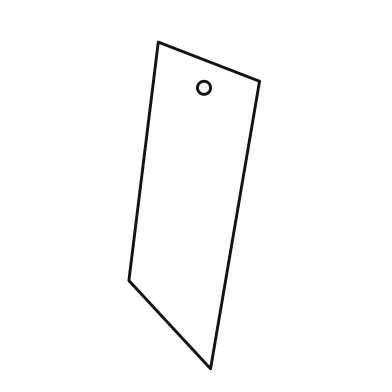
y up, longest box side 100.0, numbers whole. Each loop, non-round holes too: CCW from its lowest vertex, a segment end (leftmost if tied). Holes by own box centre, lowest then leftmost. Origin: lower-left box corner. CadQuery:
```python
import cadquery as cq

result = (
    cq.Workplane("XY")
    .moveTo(25.0, 0.0)
    .lineTo(40.0, 88.0)
    .lineTo(9.0, 100.0)
    .lineTo(0.0, 27.0)
    .close()
    .moveTo(23.0, 86.0)
    .circle(2.0)
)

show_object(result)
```